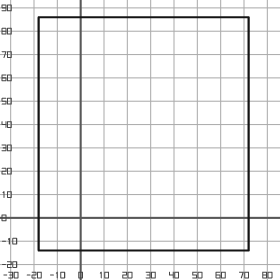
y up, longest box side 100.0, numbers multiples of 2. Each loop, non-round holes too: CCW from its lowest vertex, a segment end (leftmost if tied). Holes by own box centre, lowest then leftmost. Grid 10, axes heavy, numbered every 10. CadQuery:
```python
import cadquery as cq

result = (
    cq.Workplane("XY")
    .moveTo(-18.0, -14.0)
    .lineTo(72.0, -14.0)
    .lineTo(72.0, 86.0)
    .lineTo(-18.0, 86.0)
    .close()
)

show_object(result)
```